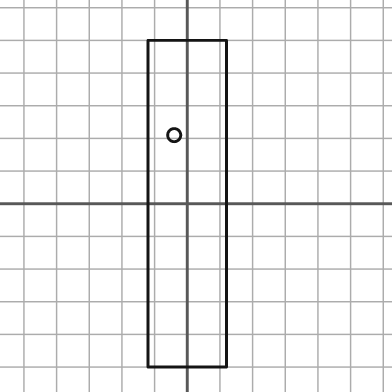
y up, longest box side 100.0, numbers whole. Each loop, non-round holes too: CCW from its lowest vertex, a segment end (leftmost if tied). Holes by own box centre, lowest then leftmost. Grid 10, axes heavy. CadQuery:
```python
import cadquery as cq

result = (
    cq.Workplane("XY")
    .moveTo(-12.0, -50.0)
    .lineTo(12.0, -50.0)
    .lineTo(12.0, 50.0)
    .lineTo(-12.0, 50.0)
    .close()
    .moveTo(-4.0, 21.0)
    .circle(2.0)
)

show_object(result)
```